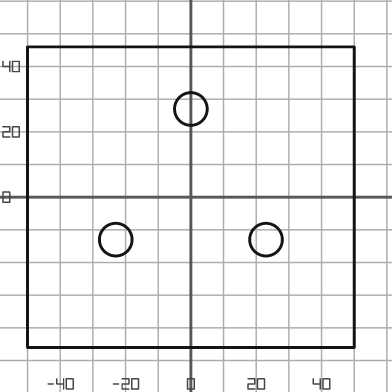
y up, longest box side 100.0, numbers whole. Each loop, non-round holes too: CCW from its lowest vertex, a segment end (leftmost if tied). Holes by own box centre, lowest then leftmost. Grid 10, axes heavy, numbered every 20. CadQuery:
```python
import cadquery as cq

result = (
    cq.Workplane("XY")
    .moveTo(-50.0, -46.0)
    .lineTo(50.0, -46.0)
    .lineTo(50.0, 46.0)
    .lineTo(-50.0, 46.0)
    .close()
    .moveTo(-23.0, -13.0)
    .circle(5.0)
    .moveTo(23.0, -13.0)
    .circle(5.0)
    .moveTo(0.0, 27.0)
    .circle(5.0)
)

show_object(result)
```